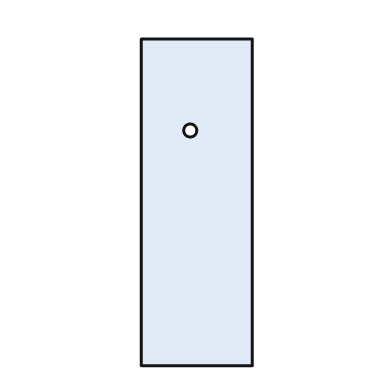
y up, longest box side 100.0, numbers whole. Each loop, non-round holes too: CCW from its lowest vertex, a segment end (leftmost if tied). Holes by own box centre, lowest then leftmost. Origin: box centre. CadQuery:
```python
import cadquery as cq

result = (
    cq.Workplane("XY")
    .moveTo(-17.0, -50.0)
    .lineTo(17.0, -50.0)
    .lineTo(17.0, 50.0)
    .lineTo(-17.0, 50.0)
    .close()
    .moveTo(-2.0, 22.0)
    .circle(2.0)
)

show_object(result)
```